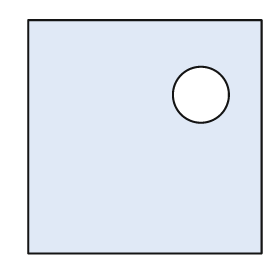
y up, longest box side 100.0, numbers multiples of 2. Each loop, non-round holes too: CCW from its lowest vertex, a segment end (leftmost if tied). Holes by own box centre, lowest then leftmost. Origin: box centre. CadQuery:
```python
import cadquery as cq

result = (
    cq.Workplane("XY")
    .moveTo(-50.0, -50.0)
    .lineTo(50.0, -50.0)
    .lineTo(50.0, 50.0)
    .lineTo(-50.0, 50.0)
    .close()
    .moveTo(24.0, 18.0)
    .circle(12.0)
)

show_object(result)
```